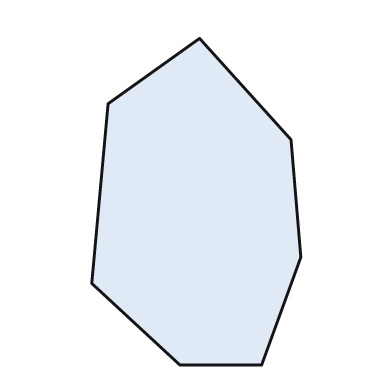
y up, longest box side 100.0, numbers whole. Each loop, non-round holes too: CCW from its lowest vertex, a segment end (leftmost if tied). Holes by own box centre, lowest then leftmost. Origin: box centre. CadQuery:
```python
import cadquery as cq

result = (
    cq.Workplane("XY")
    .moveTo(-5.0, -50.0)
    .lineTo(20.0, -50.0)
    .lineTo(32.0, -17.0)
    .lineTo(29.0, 19.0)
    .lineTo(1.0, 50.0)
    .lineTo(-27.0, 30.0)
    .lineTo(-32.0, -25.0)
    .close()
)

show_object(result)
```